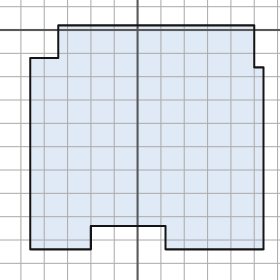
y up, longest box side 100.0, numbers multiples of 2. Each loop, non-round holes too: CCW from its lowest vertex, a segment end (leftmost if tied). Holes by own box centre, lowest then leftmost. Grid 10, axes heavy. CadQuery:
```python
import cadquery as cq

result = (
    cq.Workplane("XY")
    .moveTo(-46.0, -94.0)
    .lineTo(-20.0, -94.0)
    .lineTo(-20.0, -84.0)
    .lineTo(12.0, -84.0)
    .lineTo(12.0, -94.0)
    .lineTo(54.0, -94.0)
    .lineTo(54.0, -16.0)
    .lineTo(50.0, -16.0)
    .lineTo(50.0, 2.0)
    .lineTo(-34.0, 2.0)
    .lineTo(-34.0, -12.0)
    .lineTo(-46.0, -12.0)
    .close()
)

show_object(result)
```